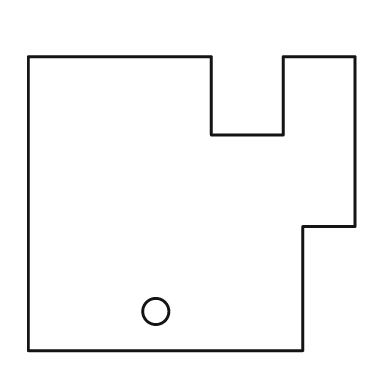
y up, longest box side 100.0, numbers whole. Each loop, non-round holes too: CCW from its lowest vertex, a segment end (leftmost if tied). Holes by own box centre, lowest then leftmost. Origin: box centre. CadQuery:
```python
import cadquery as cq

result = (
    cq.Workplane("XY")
    .moveTo(-50.0, -45.0)
    .lineTo(34.0, -45.0)
    .lineTo(34.0, -7.0)
    .lineTo(50.0, -7.0)
    .lineTo(50.0, 45.0)
    .lineTo(28.0, 45.0)
    .lineTo(28.0, 21.0)
    .lineTo(6.0, 21.0)
    .lineTo(6.0, 45.0)
    .lineTo(-50.0, 45.0)
    .close()
    .moveTo(-11.0, -33.0)
    .circle(4.0)
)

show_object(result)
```